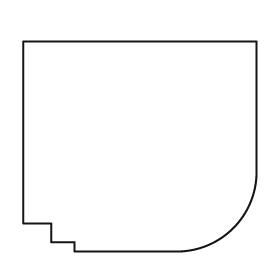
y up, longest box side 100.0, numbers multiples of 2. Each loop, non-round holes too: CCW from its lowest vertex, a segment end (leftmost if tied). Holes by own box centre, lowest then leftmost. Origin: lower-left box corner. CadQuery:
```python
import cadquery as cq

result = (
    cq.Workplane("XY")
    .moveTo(22.0, 0.0)
    .lineTo(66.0, 0.0)
    .threePointArc((90.0, 10.0), (100.0, 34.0))
    .lineTo(100.0, 90.0)
    .lineTo(0.0, 90.0)
    .lineTo(0.0, 12.0)
    .lineTo(12.0, 12.0)
    .lineTo(12.0, 4.0)
    .lineTo(22.0, 4.0)
    .close()
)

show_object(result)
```